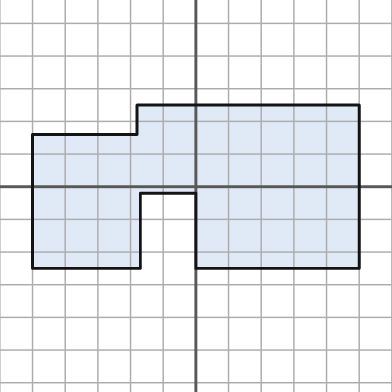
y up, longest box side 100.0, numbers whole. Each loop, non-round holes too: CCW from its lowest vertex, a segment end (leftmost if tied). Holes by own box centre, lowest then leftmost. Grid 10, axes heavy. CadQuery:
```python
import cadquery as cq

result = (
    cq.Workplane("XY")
    .moveTo(-50.0, -25.0)
    .lineTo(-17.0, -25.0)
    .lineTo(-17.0, -2.0)
    .lineTo(0.0, -2.0)
    .lineTo(0.0, -25.0)
    .lineTo(50.0, -25.0)
    .lineTo(50.0, 25.0)
    .lineTo(-18.0, 25.0)
    .lineTo(-18.0, 16.0)
    .lineTo(-50.0, 16.0)
    .close()
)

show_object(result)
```